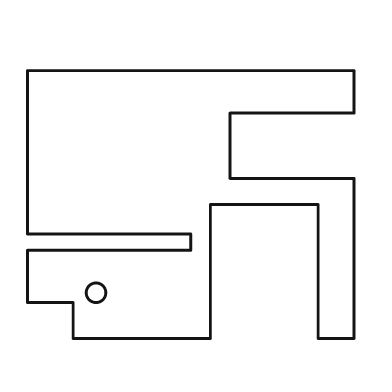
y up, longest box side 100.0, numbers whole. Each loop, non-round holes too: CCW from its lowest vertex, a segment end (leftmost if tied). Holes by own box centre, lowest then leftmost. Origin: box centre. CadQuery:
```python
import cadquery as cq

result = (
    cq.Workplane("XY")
    .moveTo(-36.0, -41.0)
    .lineTo(6.0, -41.0)
    .lineTo(6.0, 0.0)
    .lineTo(39.0, 0.0)
    .lineTo(39.0, -41.0)
    .lineTo(50.0, -41.0)
    .lineTo(50.0, 8.0)
    .lineTo(12.0, 8.0)
    .lineTo(12.0, 28.0)
    .lineTo(50.0, 28.0)
    .lineTo(50.0, 41.0)
    .lineTo(-50.0, 41.0)
    .lineTo(-50.0, -9.0)
    .lineTo(0.0, -9.0)
    .lineTo(0.0, -14.0)
    .lineTo(-50.0, -14.0)
    .lineTo(-50.0, -30.0)
    .lineTo(-36.0, -30.0)
    .close()
    .moveTo(-29.0, -27.0)
    .circle(3.0)
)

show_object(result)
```